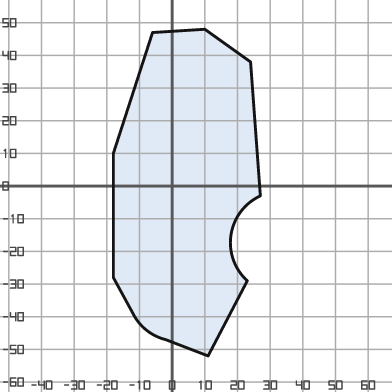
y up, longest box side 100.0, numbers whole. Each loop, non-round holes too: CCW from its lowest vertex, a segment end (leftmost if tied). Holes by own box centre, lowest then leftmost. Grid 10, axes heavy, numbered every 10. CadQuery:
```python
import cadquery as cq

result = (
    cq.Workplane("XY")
    .moveTo(11.0, -52.0)
    .lineTo(23.0, -29.0)
    .threePointArc((18.0, -15.0), (27.0, -3.0))
    .lineTo(24.0, 38.0)
    .lineTo(10.0, 48.0)
    .lineTo(-6.0, 47.0)
    .lineTo(-18.0, 10.0)
    .lineTo(-18.0, -28.0)
    .lineTo(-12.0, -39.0)
    .threePointArc((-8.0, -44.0), (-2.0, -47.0))
    .close()
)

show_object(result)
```